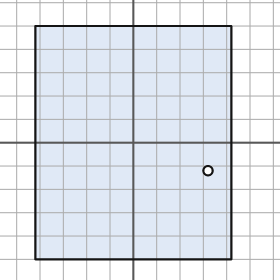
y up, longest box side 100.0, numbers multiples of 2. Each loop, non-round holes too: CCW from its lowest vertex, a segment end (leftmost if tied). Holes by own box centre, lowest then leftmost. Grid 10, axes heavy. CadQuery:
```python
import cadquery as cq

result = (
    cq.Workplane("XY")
    .moveTo(-42.0, -50.0)
    .lineTo(42.0, -50.0)
    .lineTo(42.0, 50.0)
    .lineTo(-42.0, 50.0)
    .close()
    .moveTo(32.0, -12.0)
    .circle(2.0)
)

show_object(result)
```